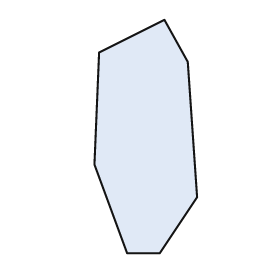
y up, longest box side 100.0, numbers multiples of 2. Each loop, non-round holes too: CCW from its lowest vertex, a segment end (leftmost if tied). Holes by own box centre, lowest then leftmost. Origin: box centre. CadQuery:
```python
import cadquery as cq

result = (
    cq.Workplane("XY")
    .moveTo(-8.0, -50.0)
    .lineTo(6.0, -50.0)
    .lineTo(22.0, -26.0)
    .lineTo(18.0, 32.0)
    .lineTo(8.0, 50.0)
    .lineTo(-20.0, 36.0)
    .lineTo(-22.0, -12.0)
    .close()
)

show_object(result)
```